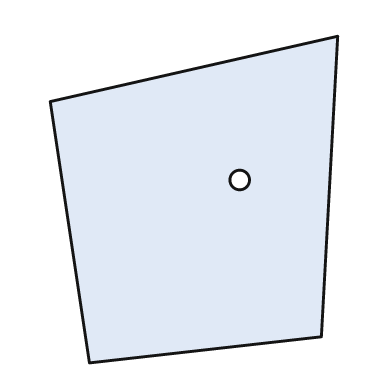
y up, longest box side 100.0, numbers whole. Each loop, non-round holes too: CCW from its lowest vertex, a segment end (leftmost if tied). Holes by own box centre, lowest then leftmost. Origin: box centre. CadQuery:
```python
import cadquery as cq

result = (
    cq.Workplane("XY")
    .moveTo(-32.0, -50.0)
    .lineTo(39.0, -42.0)
    .lineTo(44.0, 50.0)
    .lineTo(-44.0, 30.0)
    .close()
    .moveTo(14.0, 6.0)
    .circle(3.0)
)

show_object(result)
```